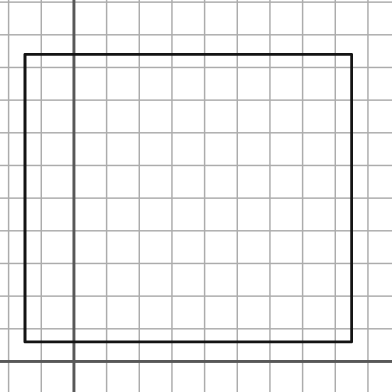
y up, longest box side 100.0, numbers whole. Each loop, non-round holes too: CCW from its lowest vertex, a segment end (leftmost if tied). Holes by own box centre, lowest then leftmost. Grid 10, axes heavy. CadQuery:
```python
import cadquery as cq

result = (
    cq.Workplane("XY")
    .moveTo(-15.0, 6.0)
    .lineTo(85.0, 6.0)
    .lineTo(85.0, 94.0)
    .lineTo(-15.0, 94.0)
    .close()
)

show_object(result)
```